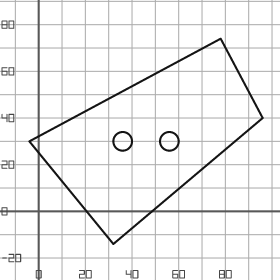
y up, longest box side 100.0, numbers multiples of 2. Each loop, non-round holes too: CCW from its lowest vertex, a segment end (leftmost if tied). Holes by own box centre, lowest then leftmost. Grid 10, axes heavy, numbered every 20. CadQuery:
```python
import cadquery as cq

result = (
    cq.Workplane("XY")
    .moveTo(32.0, -14.0)
    .lineTo(96.0, 40.0)
    .lineTo(78.0, 74.0)
    .lineTo(-4.0, 30.0)
    .close()
    .moveTo(36.0, 30.0)
    .circle(4.0)
    .moveTo(56.0, 30.0)
    .circle(4.0)
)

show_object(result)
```